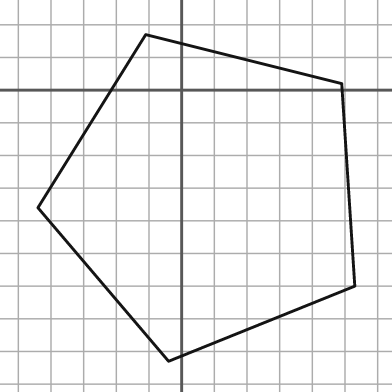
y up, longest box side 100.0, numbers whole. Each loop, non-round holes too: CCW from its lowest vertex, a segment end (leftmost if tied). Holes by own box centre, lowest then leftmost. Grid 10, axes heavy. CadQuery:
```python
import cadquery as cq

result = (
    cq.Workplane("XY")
    .moveTo(-4.0, -83.0)
    .lineTo(53.0, -60.0)
    .lineTo(49.0, 2.0)
    .lineTo(-11.0, 17.0)
    .lineTo(-44.0, -36.0)
    .close()
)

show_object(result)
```